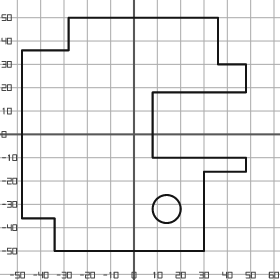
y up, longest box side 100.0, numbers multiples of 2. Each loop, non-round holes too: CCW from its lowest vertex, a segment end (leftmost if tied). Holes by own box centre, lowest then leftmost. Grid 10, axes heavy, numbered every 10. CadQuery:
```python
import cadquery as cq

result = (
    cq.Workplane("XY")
    .moveTo(-34.0, -50.0)
    .lineTo(30.0, -50.0)
    .lineTo(30.0, -16.0)
    .lineTo(48.0, -16.0)
    .lineTo(48.0, -10.0)
    .lineTo(8.0, -10.0)
    .lineTo(8.0, 18.0)
    .lineTo(48.0, 18.0)
    .lineTo(48.0, 30.0)
    .lineTo(36.0, 30.0)
    .lineTo(36.0, 50.0)
    .lineTo(-28.0, 50.0)
    .lineTo(-28.0, 36.0)
    .lineTo(-48.0, 36.0)
    .lineTo(-48.0, -36.0)
    .lineTo(-34.0, -36.0)
    .close()
    .moveTo(14.0, -32.0)
    .circle(6.0)
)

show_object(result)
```